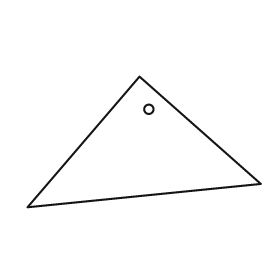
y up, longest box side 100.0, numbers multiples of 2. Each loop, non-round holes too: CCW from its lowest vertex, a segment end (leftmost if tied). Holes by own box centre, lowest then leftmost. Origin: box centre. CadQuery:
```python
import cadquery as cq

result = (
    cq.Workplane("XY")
    .moveTo(-50.0, -28.0)
    .lineTo(50.0, -18.0)
    .lineTo(-2.0, 28.0)
    .close()
    .moveTo(2.0, 14.0)
    .circle(2.0)
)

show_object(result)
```